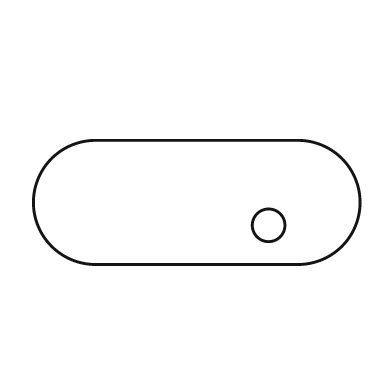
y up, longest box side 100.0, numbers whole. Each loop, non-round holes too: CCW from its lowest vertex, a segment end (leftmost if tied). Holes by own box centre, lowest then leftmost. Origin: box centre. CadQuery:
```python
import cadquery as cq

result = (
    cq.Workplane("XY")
    .moveTo(-31.0, -19.0)
    .lineTo(31.0, -19.0)
    .threePointArc((50.0, 0.0), (31.0, 19.0))
    .lineTo(-31.0, 19.0)
    .threePointArc((-50.0, 0.0), (-31.0, -19.0))
    .close()
    .moveTo(22.0, -7.0)
    .circle(5.0)
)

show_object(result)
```